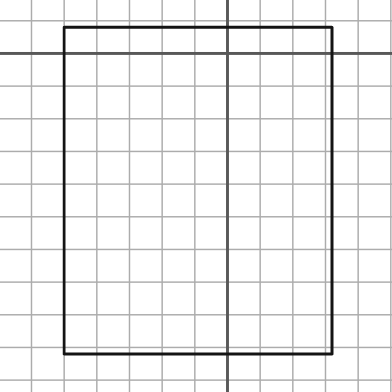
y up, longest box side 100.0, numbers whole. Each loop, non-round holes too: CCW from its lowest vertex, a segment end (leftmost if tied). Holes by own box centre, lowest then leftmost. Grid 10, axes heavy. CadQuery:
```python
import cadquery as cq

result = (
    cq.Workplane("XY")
    .moveTo(-50.0, -92.0)
    .lineTo(32.0, -92.0)
    .lineTo(32.0, 8.0)
    .lineTo(-50.0, 8.0)
    .close()
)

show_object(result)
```